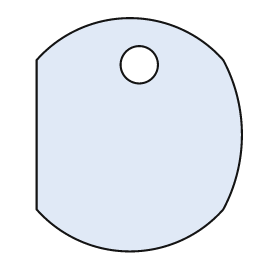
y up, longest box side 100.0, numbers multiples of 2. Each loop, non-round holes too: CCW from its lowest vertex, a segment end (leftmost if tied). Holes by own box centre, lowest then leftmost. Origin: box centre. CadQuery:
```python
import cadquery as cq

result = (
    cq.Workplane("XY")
    .moveTo(-44.0, -32.0)
    .threePointArc((-4.0, -50.0), (36.0, -32.0))
    .threePointArc((44.0, 0.0), (36.0, 32.0))
    .threePointArc((-4.0, 50.0), (-44.0, 32.0))
    .close()
    .moveTo(0.0, 30.0)
    .circle(8.0)
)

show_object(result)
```